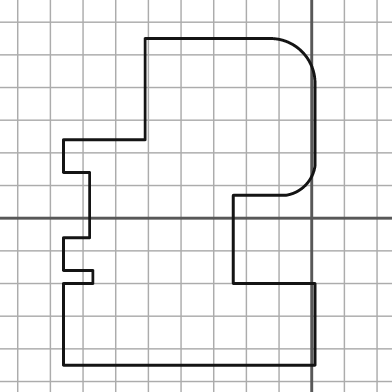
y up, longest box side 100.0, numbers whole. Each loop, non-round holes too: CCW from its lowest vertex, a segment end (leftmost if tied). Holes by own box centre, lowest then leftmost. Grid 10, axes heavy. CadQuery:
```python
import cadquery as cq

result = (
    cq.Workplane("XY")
    .moveTo(-76.0, -45.0)
    .lineTo(1.0, -45.0)
    .lineTo(1.0, -20.0)
    .lineTo(-24.0, -20.0)
    .lineTo(-24.0, 7.0)
    .lineTo(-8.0, 7.0)
    .threePointArc((-2.0, 10.0), (1.0, 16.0))
    .lineTo(1.0, 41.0)
    .threePointArc((-3.0, 51.0), (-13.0, 55.0))
    .lineTo(-51.0, 55.0)
    .lineTo(-51.0, 24.0)
    .lineTo(-76.0, 24.0)
    .lineTo(-76.0, 14.0)
    .lineTo(-68.0, 14.0)
    .lineTo(-68.0, -6.0)
    .lineTo(-76.0, -6.0)
    .lineTo(-76.0, -16.0)
    .lineTo(-67.0, -16.0)
    .lineTo(-67.0, -20.0)
    .lineTo(-76.0, -20.0)
    .close()
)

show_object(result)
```